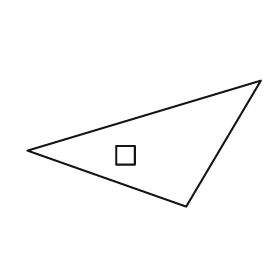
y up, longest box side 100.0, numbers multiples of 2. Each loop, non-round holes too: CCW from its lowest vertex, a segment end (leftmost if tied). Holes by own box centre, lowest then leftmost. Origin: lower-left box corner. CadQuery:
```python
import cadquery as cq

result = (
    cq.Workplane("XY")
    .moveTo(68.0, 0.0)
    .lineTo(100.0, 54.0)
    .lineTo(0.0, 24.0)
    .close()
    .moveTo(38.0, 18.0)
    .lineTo(46.0, 18.0)
    .lineTo(46.0, 26.0)
    .lineTo(38.0, 26.0)
    .close()
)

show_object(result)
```